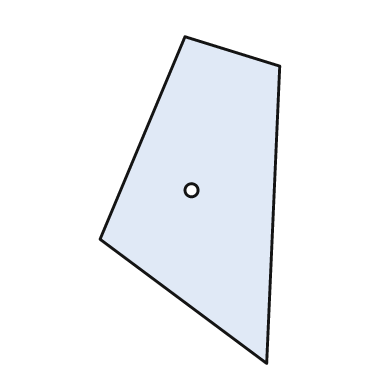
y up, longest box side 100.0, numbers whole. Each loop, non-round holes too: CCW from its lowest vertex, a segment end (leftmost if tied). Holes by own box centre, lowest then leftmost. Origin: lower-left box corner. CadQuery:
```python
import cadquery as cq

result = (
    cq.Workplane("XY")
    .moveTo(51.0, 0.0)
    .lineTo(55.0, 91.0)
    .lineTo(26.0, 100.0)
    .lineTo(0.0, 38.0)
    .close()
    .moveTo(28.0, 53.0)
    .circle(2.0)
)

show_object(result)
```